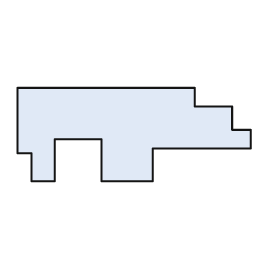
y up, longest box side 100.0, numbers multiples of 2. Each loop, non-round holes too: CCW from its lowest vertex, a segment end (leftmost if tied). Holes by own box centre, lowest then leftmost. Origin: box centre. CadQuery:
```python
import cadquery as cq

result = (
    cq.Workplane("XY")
    .moveTo(-44.0, -20.0)
    .lineTo(-34.0, -20.0)
    .lineTo(-34.0, -2.0)
    .lineTo(-14.0, -2.0)
    .lineTo(-14.0, -20.0)
    .lineTo(8.0, -20.0)
    .lineTo(8.0, -6.0)
    .lineTo(50.0, -6.0)
    .lineTo(50.0, 2.0)
    .lineTo(42.0, 2.0)
    .lineTo(42.0, 12.0)
    .lineTo(26.0, 12.0)
    .lineTo(26.0, 20.0)
    .lineTo(-50.0, 20.0)
    .lineTo(-50.0, -8.0)
    .lineTo(-44.0, -8.0)
    .close()
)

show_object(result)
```